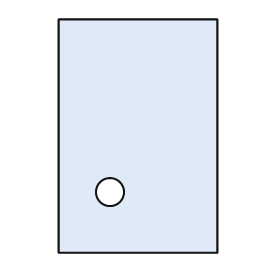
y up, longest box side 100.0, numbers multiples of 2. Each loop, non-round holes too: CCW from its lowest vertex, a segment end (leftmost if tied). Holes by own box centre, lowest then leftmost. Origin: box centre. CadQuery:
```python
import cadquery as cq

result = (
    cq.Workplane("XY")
    .moveTo(-34.0, -50.0)
    .lineTo(34.0, -50.0)
    .lineTo(34.0, 50.0)
    .lineTo(-34.0, 50.0)
    .close()
    .moveTo(-12.0, -24.0)
    .circle(6.0)
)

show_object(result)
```